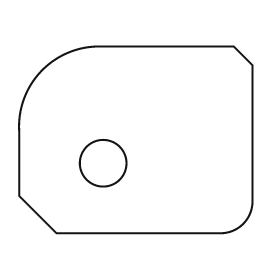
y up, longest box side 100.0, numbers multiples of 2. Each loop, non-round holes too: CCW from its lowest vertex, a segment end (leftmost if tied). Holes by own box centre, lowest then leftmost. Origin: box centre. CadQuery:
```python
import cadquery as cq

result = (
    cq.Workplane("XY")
    .moveTo(-34.0, -40.0)
    .lineTo(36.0, -40.0)
    .threePointArc((46.0, -36.0), (50.0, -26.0))
    .lineTo(50.0, 32.0)
    .lineTo(42.0, 40.0)
    .lineTo(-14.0, 40.0)
    .threePointArc((-40.0, 30.0), (-50.0, 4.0))
    .lineTo(-50.0, -24.0)
    .close()
    .moveTo(-14.0, -10.0)
    .circle(10.0)
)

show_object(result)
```